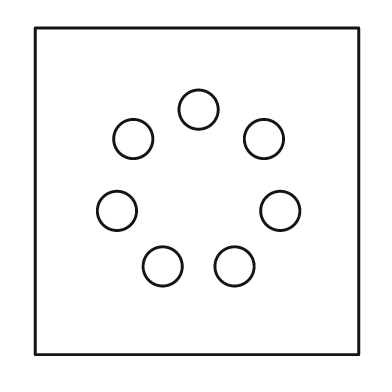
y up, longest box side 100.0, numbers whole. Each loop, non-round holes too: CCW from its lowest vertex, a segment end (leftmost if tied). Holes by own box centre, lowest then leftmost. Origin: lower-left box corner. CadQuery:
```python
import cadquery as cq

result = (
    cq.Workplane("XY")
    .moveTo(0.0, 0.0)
    .lineTo(99.0, 0.0)
    .lineTo(99.0, 100.0)
    .lineTo(0.0, 100.0)
    .close()
    .moveTo(39.0, 27.0)
    .circle(6.0)
    .moveTo(61.0, 27.0)
    .circle(6.0)
    .moveTo(25.0, 44.0)
    .circle(6.0)
    .moveTo(75.0, 44.0)
    .circle(6.0)
    .moveTo(30.0, 66.0)
    .circle(6.0)
    .moveTo(70.0, 66.0)
    .circle(6.0)
    .moveTo(50.0, 75.0)
    .circle(6.0)
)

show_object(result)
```